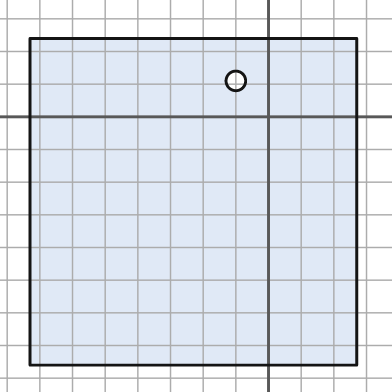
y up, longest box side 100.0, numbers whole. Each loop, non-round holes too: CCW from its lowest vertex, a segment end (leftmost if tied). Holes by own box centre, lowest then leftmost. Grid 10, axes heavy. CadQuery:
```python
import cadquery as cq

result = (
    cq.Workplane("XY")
    .moveTo(-73.0, -76.0)
    .lineTo(27.0, -76.0)
    .lineTo(27.0, 24.0)
    .lineTo(-73.0, 24.0)
    .close()
    .moveTo(-10.0, 11.0)
    .circle(3.0)
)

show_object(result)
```